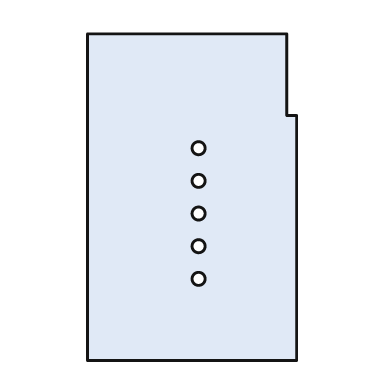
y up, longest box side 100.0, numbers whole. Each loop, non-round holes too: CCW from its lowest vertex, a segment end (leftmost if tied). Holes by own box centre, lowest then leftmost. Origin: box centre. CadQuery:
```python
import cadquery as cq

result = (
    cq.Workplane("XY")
    .moveTo(-32.0, -50.0)
    .lineTo(32.0, -50.0)
    .lineTo(32.0, 25.0)
    .lineTo(29.0, 25.0)
    .lineTo(29.0, 50.0)
    .lineTo(-32.0, 50.0)
    .close()
    .moveTo(2.0, -25.0)
    .circle(2.0)
    .moveTo(2.0, -15.0)
    .circle(2.0)
    .moveTo(2.0, -5.0)
    .circle(2.0)
    .moveTo(2.0, 5.0)
    .circle(2.0)
    .moveTo(2.0, 15.0)
    .circle(2.0)
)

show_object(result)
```